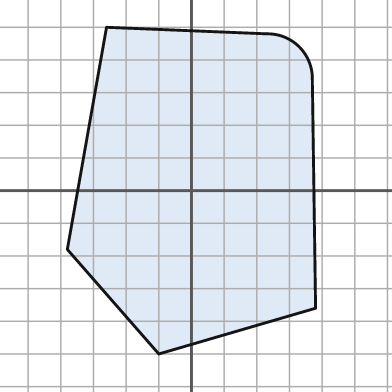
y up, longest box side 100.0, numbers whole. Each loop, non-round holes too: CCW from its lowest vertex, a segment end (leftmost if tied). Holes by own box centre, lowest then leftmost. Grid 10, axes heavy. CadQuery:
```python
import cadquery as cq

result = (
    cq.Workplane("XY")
    .moveTo(-10.0, -50.0)
    .lineTo(38.0, -36.0)
    .lineTo(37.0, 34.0)
    .threePointArc((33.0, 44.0), (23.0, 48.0))
    .lineTo(-26.0, 50.0)
    .lineTo(-38.0, -18.0)
    .close()
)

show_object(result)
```